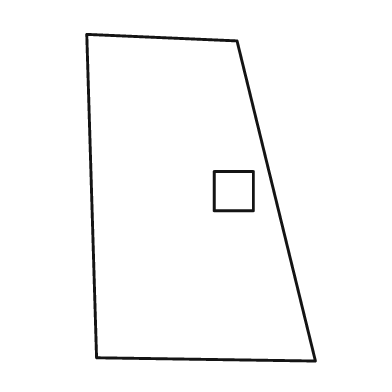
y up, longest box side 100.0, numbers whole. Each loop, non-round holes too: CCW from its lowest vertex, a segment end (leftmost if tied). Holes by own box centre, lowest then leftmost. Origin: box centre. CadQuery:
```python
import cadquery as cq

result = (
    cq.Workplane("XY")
    .moveTo(35.0, -50.0)
    .lineTo(11.0, 48.0)
    .lineTo(-35.0, 50.0)
    .lineTo(-32.0, -49.0)
    .close()
    .moveTo(4.0, -4.0)
    .lineTo(16.0, -4.0)
    .lineTo(16.0, 8.0)
    .lineTo(4.0, 8.0)
    .close()
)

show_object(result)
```